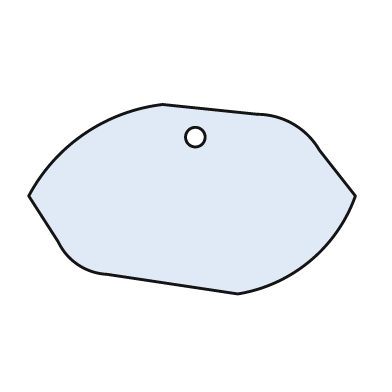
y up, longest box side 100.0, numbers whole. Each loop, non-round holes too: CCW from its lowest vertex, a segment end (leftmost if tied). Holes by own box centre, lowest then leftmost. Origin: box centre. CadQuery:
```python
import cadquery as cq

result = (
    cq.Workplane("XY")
    .moveTo(14.0, -29.0)
    .threePointArc((36.0, -19.0), (50.0, 1.0))
    .lineTo(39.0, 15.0)
    .threePointArc((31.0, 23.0), (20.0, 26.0))
    .lineTo(-9.0, 29.0)
    .threePointArc((-33.0, 20.0), (-50.0, 1.0))
    .lineTo(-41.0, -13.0)
    .threePointArc((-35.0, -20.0), (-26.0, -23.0))
    .close()
    .moveTo(1.0, 19.0)
    .circle(3.0)
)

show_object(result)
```